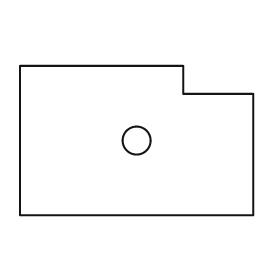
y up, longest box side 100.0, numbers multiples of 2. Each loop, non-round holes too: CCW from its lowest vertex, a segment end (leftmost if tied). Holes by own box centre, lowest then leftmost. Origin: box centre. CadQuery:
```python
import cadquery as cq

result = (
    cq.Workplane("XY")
    .moveTo(-50.0, -32.0)
    .lineTo(50.0, -32.0)
    .lineTo(50.0, 20.0)
    .lineTo(20.0, 20.0)
    .lineTo(20.0, 32.0)
    .lineTo(-50.0, 32.0)
    .close()
    .moveTo(0.0, 0.0)
    .circle(6.0)
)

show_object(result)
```